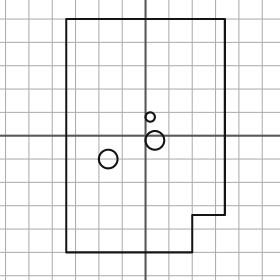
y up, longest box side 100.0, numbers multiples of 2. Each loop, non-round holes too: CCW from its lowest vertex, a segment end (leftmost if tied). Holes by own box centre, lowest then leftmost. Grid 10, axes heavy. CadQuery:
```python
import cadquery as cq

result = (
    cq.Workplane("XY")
    .moveTo(-34.0, -50.0)
    .lineTo(20.0, -50.0)
    .lineTo(20.0, -34.0)
    .lineTo(34.0, -34.0)
    .lineTo(34.0, 50.0)
    .lineTo(-34.0, 50.0)
    .close()
    .moveTo(-16.0, -10.0)
    .circle(4.0)
    .moveTo(4.0, -2.0)
    .circle(4.0)
    .moveTo(2.0, 8.0)
    .circle(2.0)
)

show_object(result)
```